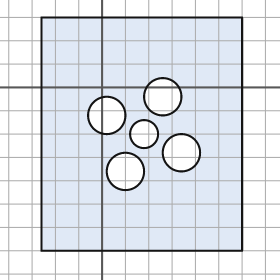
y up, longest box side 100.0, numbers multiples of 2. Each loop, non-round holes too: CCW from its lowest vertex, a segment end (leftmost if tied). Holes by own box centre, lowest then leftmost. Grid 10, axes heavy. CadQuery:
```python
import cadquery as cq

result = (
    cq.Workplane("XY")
    .moveTo(-26.0, -70.0)
    .lineTo(60.0, -70.0)
    .lineTo(60.0, 30.0)
    .lineTo(-26.0, 30.0)
    .close()
    .moveTo(10.0, -36.0)
    .circle(8.0)
    .moveTo(34.0, -28.0)
    .circle(8.0)
    .moveTo(18.0, -20.0)
    .circle(6.0)
    .moveTo(2.0, -12.0)
    .circle(8.0)
    .moveTo(26.0, -4.0)
    .circle(8.0)
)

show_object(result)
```